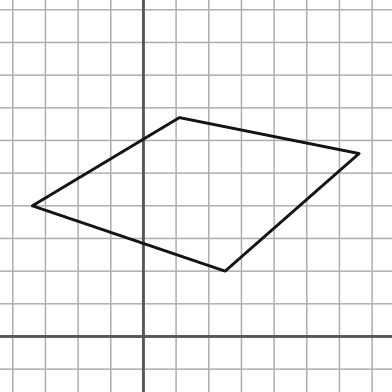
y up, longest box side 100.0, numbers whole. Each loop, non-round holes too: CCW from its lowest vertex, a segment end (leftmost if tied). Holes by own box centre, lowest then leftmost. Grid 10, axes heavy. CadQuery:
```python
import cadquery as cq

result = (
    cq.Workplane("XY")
    .moveTo(25.0, 20.0)
    .lineTo(66.0, 56.0)
    .lineTo(11.0, 67.0)
    .lineTo(-34.0, 40.0)
    .close()
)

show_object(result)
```